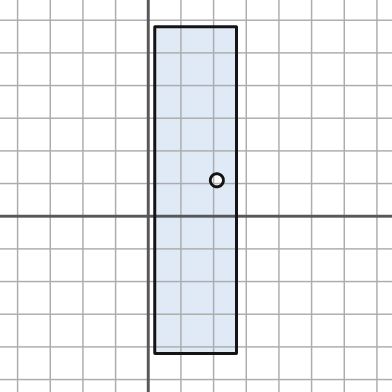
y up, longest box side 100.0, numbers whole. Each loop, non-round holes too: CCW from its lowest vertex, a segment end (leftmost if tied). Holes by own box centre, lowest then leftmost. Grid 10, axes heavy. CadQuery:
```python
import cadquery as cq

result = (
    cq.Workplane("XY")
    .moveTo(2.0, -42.0)
    .lineTo(27.0, -42.0)
    .lineTo(27.0, 58.0)
    .lineTo(2.0, 58.0)
    .close()
    .moveTo(21.0, 11.0)
    .circle(2.0)
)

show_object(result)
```